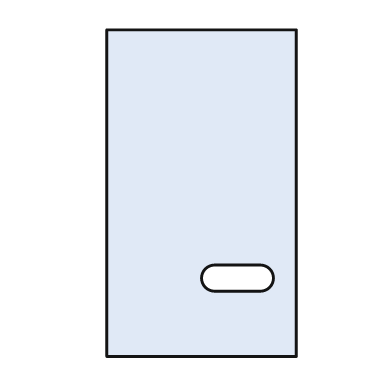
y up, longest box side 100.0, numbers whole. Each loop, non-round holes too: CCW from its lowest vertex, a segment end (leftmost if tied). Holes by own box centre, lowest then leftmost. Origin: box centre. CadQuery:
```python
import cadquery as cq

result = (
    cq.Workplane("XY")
    .moveTo(-29.0, -50.0)
    .lineTo(29.0, -50.0)
    .lineTo(29.0, 50.0)
    .lineTo(-29.0, 50.0)
    .close()
    .moveTo(4.0, -30.0)
    .lineTo(18.0, -30.0)
    .threePointArc((22.0, -26.0), (18.0, -22.0))
    .lineTo(4.0, -22.0)
    .threePointArc((0.0, -26.0), (4.0, -30.0))
    .close()
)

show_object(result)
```